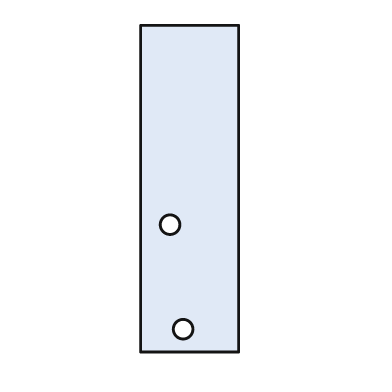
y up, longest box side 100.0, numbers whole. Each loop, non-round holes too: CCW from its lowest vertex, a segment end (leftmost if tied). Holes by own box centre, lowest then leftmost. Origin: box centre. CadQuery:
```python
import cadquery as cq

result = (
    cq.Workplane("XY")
    .moveTo(-15.0, -50.0)
    .lineTo(15.0, -50.0)
    .lineTo(15.0, 50.0)
    .lineTo(-15.0, 50.0)
    .close()
    .moveTo(-2.0, -43.0)
    .circle(3.0)
    .moveTo(-6.0, -11.0)
    .circle(3.0)
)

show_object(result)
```